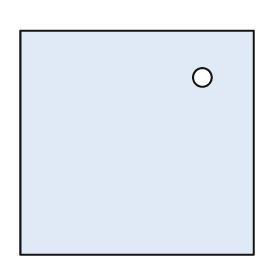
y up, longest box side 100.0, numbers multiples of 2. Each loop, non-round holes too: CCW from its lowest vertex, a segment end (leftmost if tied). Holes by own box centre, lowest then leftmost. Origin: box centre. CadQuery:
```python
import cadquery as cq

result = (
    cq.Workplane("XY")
    .moveTo(-50.0, -48.0)
    .lineTo(50.0, -48.0)
    .lineTo(50.0, 48.0)
    .lineTo(-50.0, 48.0)
    .close()
    .moveTo(28.0, 28.0)
    .circle(4.0)
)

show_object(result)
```